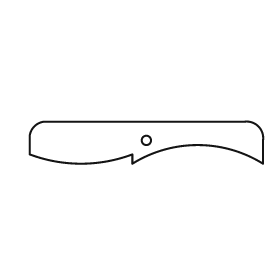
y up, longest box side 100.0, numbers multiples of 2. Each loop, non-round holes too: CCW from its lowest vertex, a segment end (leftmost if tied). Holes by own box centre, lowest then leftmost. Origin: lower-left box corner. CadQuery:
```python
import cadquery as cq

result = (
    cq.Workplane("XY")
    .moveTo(44.0, 0.0)
    .threePointArc((72.0, 8.0), (100.0, 0.0))
    .lineTo(100.0, 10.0)
    .threePointArc((98.0, 16.0), (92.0, 18.0))
    .lineTo(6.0, 18.0)
    .threePointArc((2.0, 16.0), (0.0, 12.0))
    .lineTo(0.0, 4.0)
    .threePointArc((22.0, 0.0), (44.0, 4.0))
    .close()
    .moveTo(50.0, 10.0)
    .circle(2.0)
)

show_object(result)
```